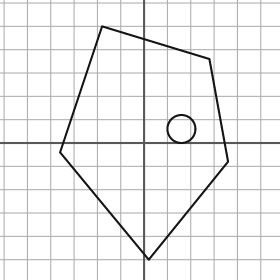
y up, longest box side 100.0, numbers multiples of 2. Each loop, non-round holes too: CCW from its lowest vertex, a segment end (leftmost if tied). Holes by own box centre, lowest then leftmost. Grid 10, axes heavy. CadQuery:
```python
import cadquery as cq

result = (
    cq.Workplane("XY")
    .moveTo(2.0, -50.0)
    .lineTo(36.0, -8.0)
    .lineTo(28.0, 36.0)
    .lineTo(-18.0, 50.0)
    .lineTo(-36.0, -4.0)
    .close()
    .moveTo(16.0, 6.0)
    .circle(6.0)
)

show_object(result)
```